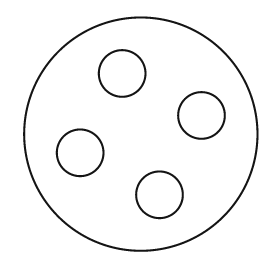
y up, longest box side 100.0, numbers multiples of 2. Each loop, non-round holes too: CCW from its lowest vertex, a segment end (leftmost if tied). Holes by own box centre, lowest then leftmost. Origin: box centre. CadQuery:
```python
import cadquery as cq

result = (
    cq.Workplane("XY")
    .moveTo(0.0, 0.0)
    .circle(50.0)
    .moveTo(8.0, -26.0)
    .circle(10.0)
    .moveTo(-26.0, -8.0)
    .circle(10.0)
    .moveTo(26.0, 8.0)
    .circle(10.0)
    .moveTo(-8.0, 26.0)
    .circle(10.0)
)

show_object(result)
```